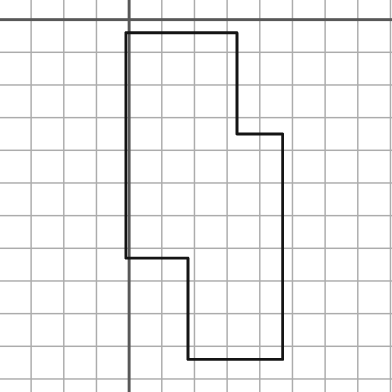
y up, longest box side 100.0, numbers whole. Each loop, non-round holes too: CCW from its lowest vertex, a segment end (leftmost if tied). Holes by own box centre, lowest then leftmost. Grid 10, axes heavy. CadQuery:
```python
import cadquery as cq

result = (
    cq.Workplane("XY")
    .moveTo(18.0, -104.0)
    .lineTo(47.0, -104.0)
    .lineTo(47.0, -35.0)
    .lineTo(33.0, -35.0)
    .lineTo(33.0, -4.0)
    .lineTo(-1.0, -4.0)
    .lineTo(-1.0, -73.0)
    .lineTo(18.0, -73.0)
    .close()
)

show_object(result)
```